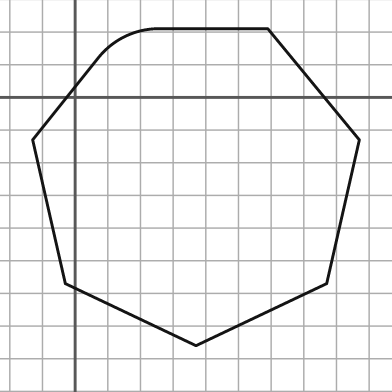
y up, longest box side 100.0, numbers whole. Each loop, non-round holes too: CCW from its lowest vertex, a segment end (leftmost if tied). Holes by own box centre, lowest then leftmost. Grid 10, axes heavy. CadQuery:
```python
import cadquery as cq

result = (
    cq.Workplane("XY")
    .moveTo(37.0, -76.0)
    .lineTo(77.0, -57.0)
    .lineTo(87.0, -13.0)
    .lineTo(59.0, 21.0)
    .lineTo(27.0, 21.0)
    .threePointArc((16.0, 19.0), (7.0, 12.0))
    .lineTo(-13.0, -13.0)
    .lineTo(-3.0, -57.0)
    .close()
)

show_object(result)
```